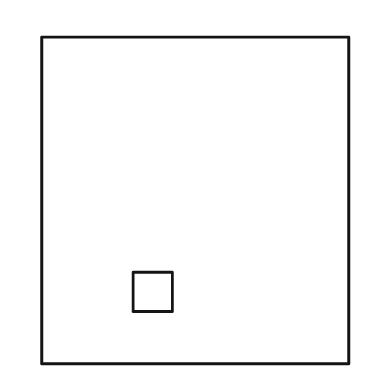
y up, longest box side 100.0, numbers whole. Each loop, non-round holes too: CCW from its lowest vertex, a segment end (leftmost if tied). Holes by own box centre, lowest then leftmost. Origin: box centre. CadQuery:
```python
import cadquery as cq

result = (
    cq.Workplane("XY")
    .moveTo(-47.0, -50.0)
    .lineTo(47.0, -50.0)
    .lineTo(47.0, 50.0)
    .lineTo(-47.0, 50.0)
    .close()
    .moveTo(-19.0, -34.0)
    .lineTo(-7.0, -34.0)
    .lineTo(-7.0, -22.0)
    .lineTo(-19.0, -22.0)
    .close()
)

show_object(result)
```